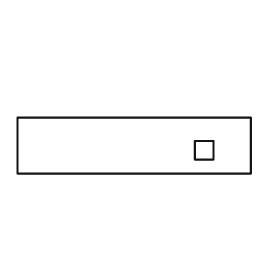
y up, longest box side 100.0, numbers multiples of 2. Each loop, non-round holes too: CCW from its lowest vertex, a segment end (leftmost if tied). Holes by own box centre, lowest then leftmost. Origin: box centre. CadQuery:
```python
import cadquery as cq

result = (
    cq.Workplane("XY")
    .moveTo(-50.0, -12.0)
    .lineTo(50.0, -12.0)
    .lineTo(50.0, 12.0)
    .lineTo(-50.0, 12.0)
    .close()
    .moveTo(26.0, -6.0)
    .lineTo(34.0, -6.0)
    .lineTo(34.0, 2.0)
    .lineTo(26.0, 2.0)
    .close()
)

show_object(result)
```